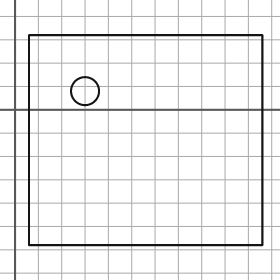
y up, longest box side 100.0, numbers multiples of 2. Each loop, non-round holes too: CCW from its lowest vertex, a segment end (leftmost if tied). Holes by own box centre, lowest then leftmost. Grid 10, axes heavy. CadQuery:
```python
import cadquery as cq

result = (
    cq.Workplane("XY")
    .moveTo(6.0, -58.0)
    .lineTo(106.0, -58.0)
    .lineTo(106.0, 32.0)
    .lineTo(6.0, 32.0)
    .close()
    .moveTo(30.0, 8.0)
    .circle(6.0)
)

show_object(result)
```